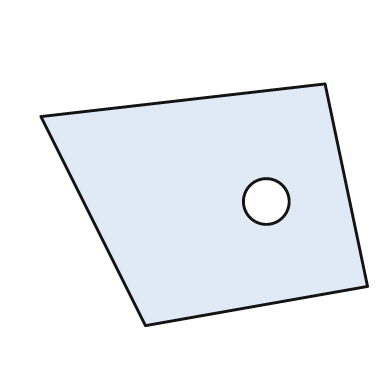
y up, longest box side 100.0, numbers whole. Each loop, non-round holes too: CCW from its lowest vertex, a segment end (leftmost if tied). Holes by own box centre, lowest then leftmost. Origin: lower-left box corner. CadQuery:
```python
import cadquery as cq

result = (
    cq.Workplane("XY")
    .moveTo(32.0, 0.0)
    .lineTo(100.0, 12.0)
    .lineTo(87.0, 74.0)
    .lineTo(0.0, 64.0)
    .close()
    .moveTo(69.0, 38.0)
    .circle(7.0)
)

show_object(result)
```